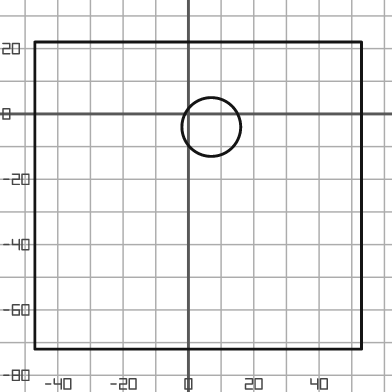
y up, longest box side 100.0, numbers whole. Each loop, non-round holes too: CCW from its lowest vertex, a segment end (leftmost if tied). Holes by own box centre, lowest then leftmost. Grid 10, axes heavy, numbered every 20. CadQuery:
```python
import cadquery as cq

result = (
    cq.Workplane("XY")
    .moveTo(-47.0, -72.0)
    .lineTo(53.0, -72.0)
    .lineTo(53.0, 22.0)
    .lineTo(-47.0, 22.0)
    .close()
    .moveTo(7.0, -4.0)
    .circle(9.0)
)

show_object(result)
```